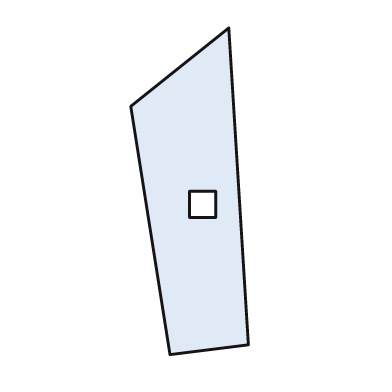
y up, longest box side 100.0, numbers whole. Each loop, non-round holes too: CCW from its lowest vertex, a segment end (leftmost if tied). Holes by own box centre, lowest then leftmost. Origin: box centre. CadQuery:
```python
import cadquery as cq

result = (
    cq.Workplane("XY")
    .moveTo(-6.0, -50.0)
    .lineTo(18.0, -47.0)
    .lineTo(12.0, 50.0)
    .lineTo(-18.0, 26.0)
    .close()
    .moveTo(0.0, -8.0)
    .lineTo(8.0, -8.0)
    .lineTo(8.0, 0.0)
    .lineTo(0.0, 0.0)
    .close()
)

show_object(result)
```